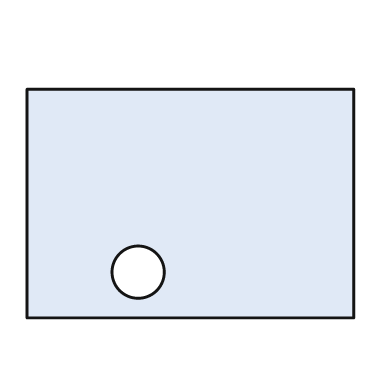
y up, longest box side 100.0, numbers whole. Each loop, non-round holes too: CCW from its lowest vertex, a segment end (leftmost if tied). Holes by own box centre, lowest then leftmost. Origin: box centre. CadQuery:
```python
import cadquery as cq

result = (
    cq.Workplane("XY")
    .moveTo(-50.0, -35.0)
    .lineTo(50.0, -35.0)
    .lineTo(50.0, 35.0)
    .lineTo(-50.0, 35.0)
    .close()
    .moveTo(-16.0, -21.0)
    .circle(8.0)
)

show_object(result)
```